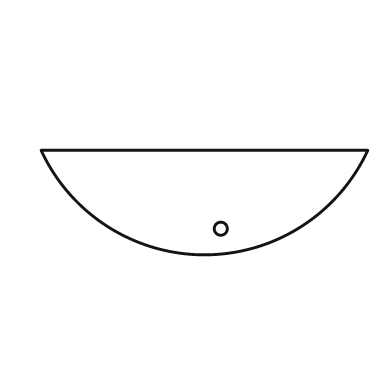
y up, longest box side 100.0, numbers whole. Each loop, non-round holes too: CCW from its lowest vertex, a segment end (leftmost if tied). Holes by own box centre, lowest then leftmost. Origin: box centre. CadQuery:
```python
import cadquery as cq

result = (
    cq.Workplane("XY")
    .moveTo(-50.0, 16.0)
    .threePointArc((0.0, -16.0), (50.0, 16.0))
    .close()
    .moveTo(5.0, -8.0)
    .circle(2.0)
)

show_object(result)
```